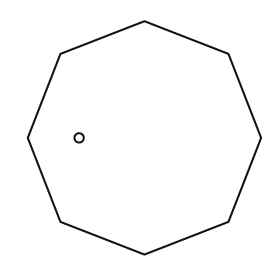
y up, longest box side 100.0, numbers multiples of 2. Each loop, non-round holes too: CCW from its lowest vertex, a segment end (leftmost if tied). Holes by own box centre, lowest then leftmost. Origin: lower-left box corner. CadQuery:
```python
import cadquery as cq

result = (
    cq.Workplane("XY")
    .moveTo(50.0, 0.0)
    .lineTo(86.0, 14.0)
    .lineTo(100.0, 50.0)
    .lineTo(86.0, 86.0)
    .lineTo(50.0, 100.0)
    .lineTo(14.0, 86.0)
    .lineTo(0.0, 50.0)
    .lineTo(14.0, 14.0)
    .close()
    .moveTo(22.0, 50.0)
    .circle(2.0)
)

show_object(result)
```